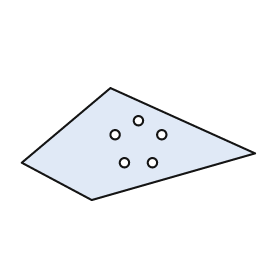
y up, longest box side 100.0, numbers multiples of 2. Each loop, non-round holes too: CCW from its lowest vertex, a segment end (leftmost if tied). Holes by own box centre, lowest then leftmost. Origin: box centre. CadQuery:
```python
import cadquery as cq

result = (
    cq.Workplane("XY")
    .moveTo(-20.0, -24.0)
    .lineTo(50.0, -4.0)
    .lineTo(-12.0, 24.0)
    .lineTo(-50.0, -8.0)
    .close()
    .moveTo(-6.0, -8.0)
    .circle(2.0)
    .moveTo(6.0, -8.0)
    .circle(2.0)
    .moveTo(-10.0, 4.0)
    .circle(2.0)
    .moveTo(10.0, 4.0)
    .circle(2.0)
    .moveTo(0.0, 10.0)
    .circle(2.0)
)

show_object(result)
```